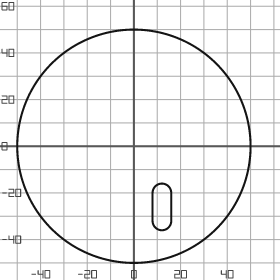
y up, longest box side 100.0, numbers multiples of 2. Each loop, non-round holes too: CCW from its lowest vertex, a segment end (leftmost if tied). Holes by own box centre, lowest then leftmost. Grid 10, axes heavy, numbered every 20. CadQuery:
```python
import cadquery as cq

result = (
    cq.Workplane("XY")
    .moveTo(0.0, 0.0)
    .circle(50.0)
    .moveTo(8.0, -32.0)
    .threePointArc((12.0, -36.0), (16.0, -32.0))
    .lineTo(16.0, -20.0)
    .threePointArc((12.0, -16.0), (8.0, -20.0))
    .close()
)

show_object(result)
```